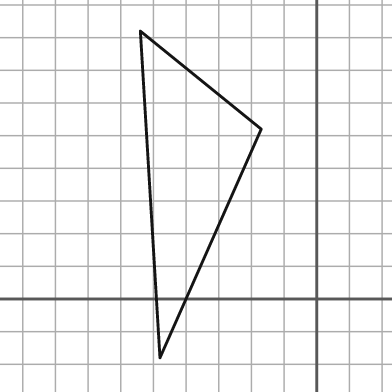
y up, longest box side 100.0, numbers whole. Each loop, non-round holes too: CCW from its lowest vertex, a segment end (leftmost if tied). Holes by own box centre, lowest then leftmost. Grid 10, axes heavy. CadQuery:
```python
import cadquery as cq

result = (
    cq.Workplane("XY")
    .moveTo(-48.0, -18.0)
    .lineTo(-17.0, 52.0)
    .lineTo(-54.0, 82.0)
    .close()
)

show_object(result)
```